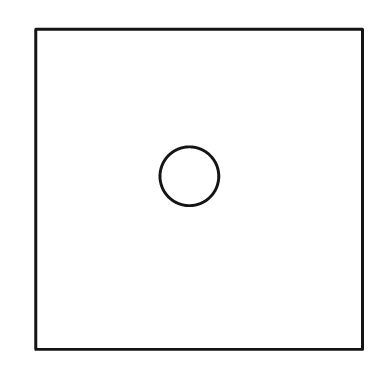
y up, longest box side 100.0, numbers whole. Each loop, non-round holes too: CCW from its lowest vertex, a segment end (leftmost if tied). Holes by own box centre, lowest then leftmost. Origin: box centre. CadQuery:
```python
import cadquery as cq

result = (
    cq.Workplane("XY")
    .moveTo(-50.0, -49.0)
    .lineTo(50.0, -49.0)
    .lineTo(50.0, 49.0)
    .lineTo(-50.0, 49.0)
    .close()
    .moveTo(-3.0, 4.0)
    .circle(9.0)
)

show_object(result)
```